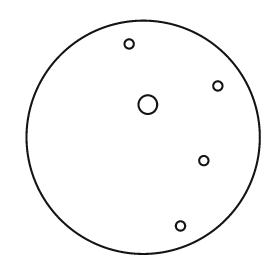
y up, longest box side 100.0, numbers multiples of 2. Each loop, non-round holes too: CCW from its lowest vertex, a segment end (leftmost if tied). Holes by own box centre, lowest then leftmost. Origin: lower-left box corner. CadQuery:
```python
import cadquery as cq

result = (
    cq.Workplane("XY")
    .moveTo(50.0, 50.0)
    .circle(50.0)
    .moveTo(66.0, 12.0)
    .circle(2.0)
    .moveTo(76.0, 40.0)
    .circle(2.0)
    .moveTo(52.0, 64.0)
    .circle(4.0)
    .moveTo(82.0, 72.0)
    .circle(2.0)
    .moveTo(44.0, 90.0)
    .circle(2.0)
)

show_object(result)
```